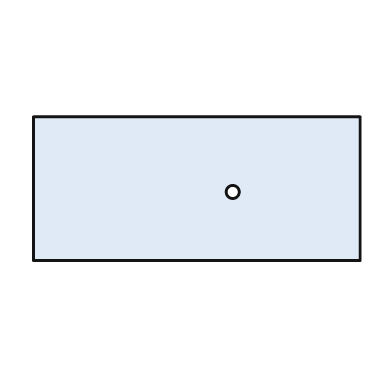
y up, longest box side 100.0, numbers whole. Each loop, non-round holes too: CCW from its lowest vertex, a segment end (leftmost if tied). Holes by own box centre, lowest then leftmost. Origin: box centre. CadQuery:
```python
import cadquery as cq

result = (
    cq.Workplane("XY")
    .moveTo(-50.0, -22.0)
    .lineTo(50.0, -22.0)
    .lineTo(50.0, 22.0)
    .lineTo(-50.0, 22.0)
    .close()
    .moveTo(11.0, -1.0)
    .circle(2.0)
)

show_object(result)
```